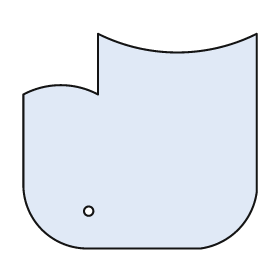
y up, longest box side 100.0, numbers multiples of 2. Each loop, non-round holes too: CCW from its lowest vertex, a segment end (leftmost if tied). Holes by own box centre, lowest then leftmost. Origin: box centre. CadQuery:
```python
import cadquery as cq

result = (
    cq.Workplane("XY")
    .moveTo(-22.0, -46.0)
    .lineTo(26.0, -46.0)
    .threePointArc((42.0, -38.0), (50.0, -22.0))
    .lineTo(50.0, 46.0)
    .threePointArc((16.0, 38.0), (-18.0, 46.0))
    .lineTo(-18.0, 20.0)
    .threePointArc((-34.0, 24.0), (-50.0, 20.0))
    .lineTo(-50.0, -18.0)
    .threePointArc((-42.0, -38.0), (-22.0, -46.0))
    .close()
    .moveTo(-22.0, -30.0)
    .circle(2.0)
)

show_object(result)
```